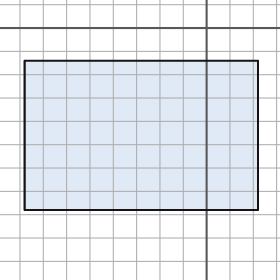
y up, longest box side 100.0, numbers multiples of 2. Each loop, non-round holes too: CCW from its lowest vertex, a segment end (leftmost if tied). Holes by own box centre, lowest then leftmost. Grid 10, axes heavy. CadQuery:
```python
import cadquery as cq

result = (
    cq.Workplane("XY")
    .moveTo(-78.0, -78.0)
    .lineTo(22.0, -78.0)
    .lineTo(22.0, -14.0)
    .lineTo(-78.0, -14.0)
    .close()
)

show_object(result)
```